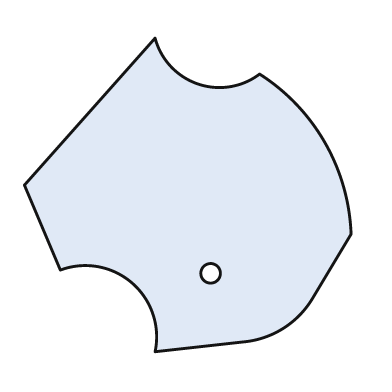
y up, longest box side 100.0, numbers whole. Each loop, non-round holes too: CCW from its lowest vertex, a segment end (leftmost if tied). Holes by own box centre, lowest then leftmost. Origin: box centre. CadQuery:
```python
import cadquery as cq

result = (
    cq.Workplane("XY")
    .moveTo(-10.0, -48.0)
    .lineTo(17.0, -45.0)
    .threePointArc((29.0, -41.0), (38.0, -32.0))
    .lineTo(50.0, -12.0)
    .threePointArc((42.0, 16.0), (22.0, 37.0))
    .threePointArc((3.0, 34.0), (-10.0, 48.0))
    .lineTo(-50.0, 3.0)
    .lineTo(-39.0, -23.0)
    .threePointArc((-17.0, -27.0), (-10.0, -48.0))
    .close()
    .moveTo(7.0, -24.0)
    .circle(3.0)
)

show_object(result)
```